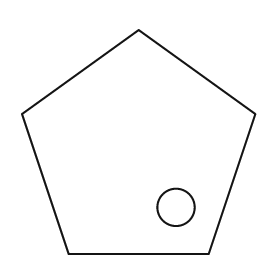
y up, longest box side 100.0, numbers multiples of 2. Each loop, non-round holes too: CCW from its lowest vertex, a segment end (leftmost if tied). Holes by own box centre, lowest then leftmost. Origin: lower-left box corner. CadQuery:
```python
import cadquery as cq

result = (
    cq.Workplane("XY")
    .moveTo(20.0, 0.0)
    .lineTo(80.0, 0.0)
    .lineTo(100.0, 60.0)
    .lineTo(50.0, 96.0)
    .lineTo(0.0, 60.0)
    .close()
    .moveTo(66.0, 20.0)
    .circle(8.0)
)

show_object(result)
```